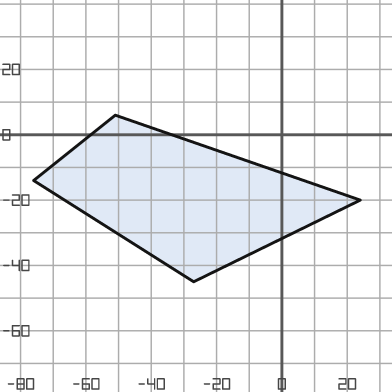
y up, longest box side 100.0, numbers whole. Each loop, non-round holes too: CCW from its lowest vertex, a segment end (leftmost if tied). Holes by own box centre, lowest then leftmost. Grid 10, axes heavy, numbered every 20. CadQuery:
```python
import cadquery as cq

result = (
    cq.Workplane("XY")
    .moveTo(-27.0, -45.0)
    .lineTo(24.0, -20.0)
    .lineTo(-51.0, 6.0)
    .lineTo(-76.0, -14.0)
    .close()
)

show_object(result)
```